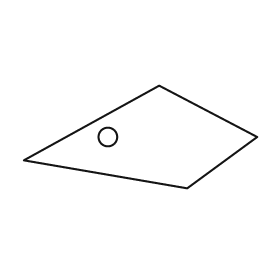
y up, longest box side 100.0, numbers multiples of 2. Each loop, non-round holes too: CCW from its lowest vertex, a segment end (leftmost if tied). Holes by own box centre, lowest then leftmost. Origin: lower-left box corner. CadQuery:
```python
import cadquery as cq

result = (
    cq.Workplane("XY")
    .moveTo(70.0, 0.0)
    .lineTo(100.0, 22.0)
    .lineTo(58.0, 44.0)
    .lineTo(0.0, 12.0)
    .close()
    .moveTo(36.0, 22.0)
    .circle(4.0)
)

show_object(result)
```